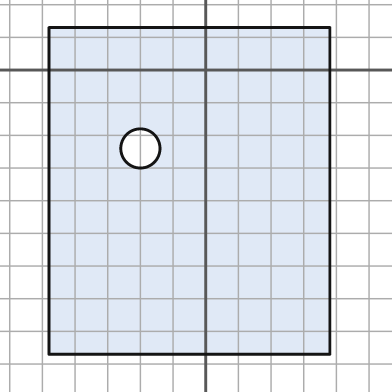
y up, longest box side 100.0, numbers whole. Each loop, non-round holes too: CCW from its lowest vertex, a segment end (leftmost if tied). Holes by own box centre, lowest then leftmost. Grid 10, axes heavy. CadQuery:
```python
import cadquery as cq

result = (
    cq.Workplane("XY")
    .moveTo(-48.0, -87.0)
    .lineTo(38.0, -87.0)
    .lineTo(38.0, 13.0)
    .lineTo(-48.0, 13.0)
    .close()
    .moveTo(-20.0, -24.0)
    .circle(6.0)
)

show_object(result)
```